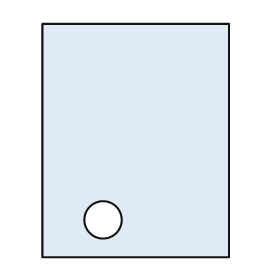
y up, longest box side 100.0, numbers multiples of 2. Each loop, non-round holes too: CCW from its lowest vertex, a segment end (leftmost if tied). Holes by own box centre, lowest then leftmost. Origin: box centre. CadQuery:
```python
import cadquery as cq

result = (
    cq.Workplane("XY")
    .moveTo(-40.0, -50.0)
    .lineTo(40.0, -50.0)
    .lineTo(40.0, 50.0)
    .lineTo(-40.0, 50.0)
    .close()
    .moveTo(-14.0, -34.0)
    .circle(8.0)
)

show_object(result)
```